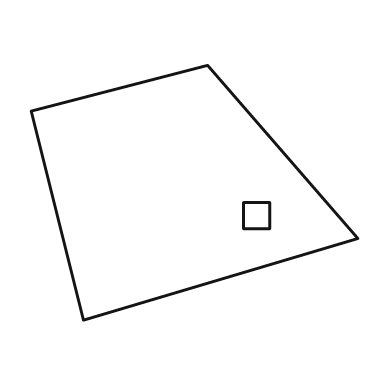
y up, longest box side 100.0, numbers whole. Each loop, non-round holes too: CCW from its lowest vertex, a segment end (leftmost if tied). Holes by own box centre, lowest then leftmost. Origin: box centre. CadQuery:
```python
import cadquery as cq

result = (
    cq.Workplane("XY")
    .moveTo(-34.0, -39.0)
    .lineTo(50.0, -14.0)
    .lineTo(4.0, 39.0)
    .lineTo(-50.0, 25.0)
    .close()
    .moveTo(15.0, -11.0)
    .lineTo(23.0, -11.0)
    .lineTo(23.0, -3.0)
    .lineTo(15.0, -3.0)
    .close()
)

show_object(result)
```